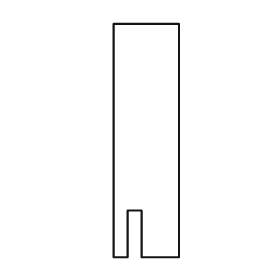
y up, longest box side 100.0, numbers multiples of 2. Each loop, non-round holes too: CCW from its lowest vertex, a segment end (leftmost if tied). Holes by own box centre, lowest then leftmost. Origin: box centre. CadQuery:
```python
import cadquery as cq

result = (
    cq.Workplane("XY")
    .moveTo(-14.0, -50.0)
    .lineTo(-8.0, -50.0)
    .lineTo(-8.0, -30.0)
    .lineTo(-2.0, -30.0)
    .lineTo(-2.0, -50.0)
    .lineTo(14.0, -50.0)
    .lineTo(14.0, 50.0)
    .lineTo(-14.0, 50.0)
    .close()
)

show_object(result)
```